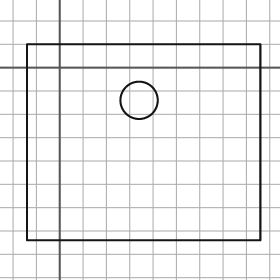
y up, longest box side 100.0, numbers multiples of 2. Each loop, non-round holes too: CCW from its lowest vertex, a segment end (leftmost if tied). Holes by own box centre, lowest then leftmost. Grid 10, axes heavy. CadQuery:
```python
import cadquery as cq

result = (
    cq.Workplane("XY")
    .moveTo(-14.0, -74.0)
    .lineTo(86.0, -74.0)
    .lineTo(86.0, 10.0)
    .lineTo(-14.0, 10.0)
    .close()
    .moveTo(34.0, -14.0)
    .circle(8.0)
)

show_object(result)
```